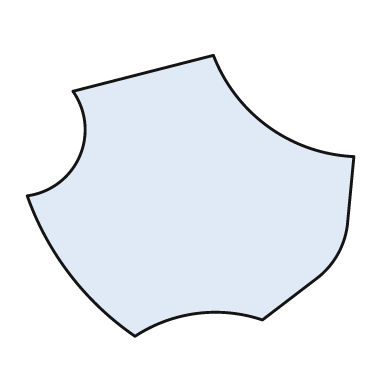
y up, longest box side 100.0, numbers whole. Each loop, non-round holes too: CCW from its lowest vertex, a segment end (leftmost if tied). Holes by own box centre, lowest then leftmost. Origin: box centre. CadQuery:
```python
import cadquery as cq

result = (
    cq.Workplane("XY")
    .moveTo(-17.0, -43.0)
    .threePointArc((2.0, -36.0), (22.0, -38.0))
    .lineTo(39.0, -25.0)
    .threePointArc((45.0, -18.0), (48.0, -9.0))
    .lineTo(50.0, 12.0)
    .threePointArc((24.0, 21.0), (7.0, 43.0))
    .lineTo(-36.0, 32.0)
    .threePointArc((-34.0, 12.0), (-50.0, 0.0))
    .threePointArc((-37.0, -24.0), (-17.0, -43.0))
    .close()
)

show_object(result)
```